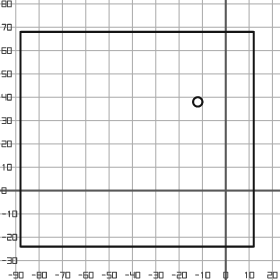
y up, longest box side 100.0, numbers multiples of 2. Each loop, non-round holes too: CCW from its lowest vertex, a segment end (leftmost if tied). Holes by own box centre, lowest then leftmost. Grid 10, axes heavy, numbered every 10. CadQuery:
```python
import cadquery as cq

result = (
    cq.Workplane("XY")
    .moveTo(-88.0, -24.0)
    .lineTo(12.0, -24.0)
    .lineTo(12.0, 68.0)
    .lineTo(-88.0, 68.0)
    .close()
    .moveTo(-12.0, 38.0)
    .circle(2.0)
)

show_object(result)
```